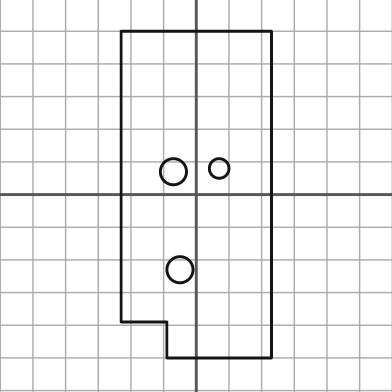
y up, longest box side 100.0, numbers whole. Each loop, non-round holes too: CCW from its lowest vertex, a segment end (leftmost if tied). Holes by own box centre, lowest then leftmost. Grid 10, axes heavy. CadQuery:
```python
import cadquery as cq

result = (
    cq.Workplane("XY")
    .moveTo(-9.0, -50.0)
    .lineTo(23.0, -50.0)
    .lineTo(23.0, 50.0)
    .lineTo(-23.0, 50.0)
    .lineTo(-23.0, -39.0)
    .lineTo(-9.0, -39.0)
    .close()
    .moveTo(-5.0, -23.0)
    .circle(4.0)
    .moveTo(-7.0, 7.0)
    .circle(4.0)
    .moveTo(7.0, 8.0)
    .circle(3.0)
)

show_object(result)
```